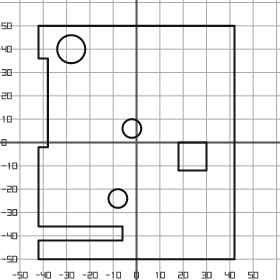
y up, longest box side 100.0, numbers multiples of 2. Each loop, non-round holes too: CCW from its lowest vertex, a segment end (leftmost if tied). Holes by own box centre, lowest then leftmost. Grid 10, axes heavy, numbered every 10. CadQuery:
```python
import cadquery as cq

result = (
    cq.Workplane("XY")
    .moveTo(-42.0, -50.0)
    .lineTo(42.0, -50.0)
    .lineTo(42.0, 50.0)
    .lineTo(-42.0, 50.0)
    .lineTo(-42.0, 36.0)
    .lineTo(-38.0, 36.0)
    .lineTo(-38.0, -2.0)
    .lineTo(-42.0, -2.0)
    .lineTo(-42.0, -36.0)
    .lineTo(-6.0, -36.0)
    .lineTo(-6.0, -42.0)
    .lineTo(-42.0, -42.0)
    .close()
    .moveTo(-8.0, -24.0)
    .circle(4.0)
    .moveTo(18.0, -12.0)
    .lineTo(30.0, -12.0)
    .lineTo(30.0, 0.0)
    .lineTo(18.0, 0.0)
    .close()
    .moveTo(-2.0, 6.0)
    .circle(4.0)
    .moveTo(-28.0, 40.0)
    .circle(6.0)
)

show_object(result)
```